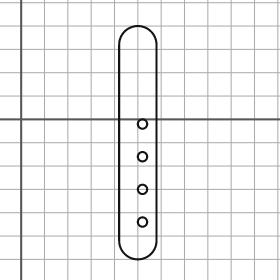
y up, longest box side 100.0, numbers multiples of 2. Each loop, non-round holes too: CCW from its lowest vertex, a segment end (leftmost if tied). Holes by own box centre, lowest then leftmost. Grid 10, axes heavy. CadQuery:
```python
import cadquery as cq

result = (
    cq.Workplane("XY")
    .moveTo(42.0, -52.0)
    .threePointArc((50.0, -60.0), (58.0, -52.0))
    .lineTo(58.0, 32.0)
    .threePointArc((50.0, 40.0), (42.0, 32.0))
    .close()
    .moveTo(52.0, -44.0)
    .circle(2.0)
    .moveTo(52.0, -30.0)
    .circle(2.0)
    .moveTo(52.0, -16.0)
    .circle(2.0)
    .moveTo(52.0, -2.0)
    .circle(2.0)
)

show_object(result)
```